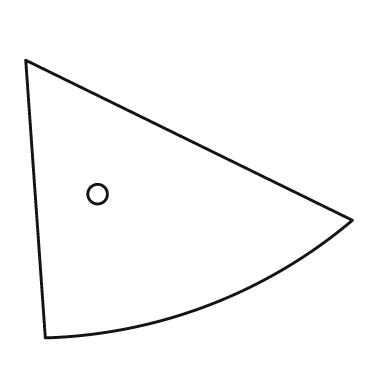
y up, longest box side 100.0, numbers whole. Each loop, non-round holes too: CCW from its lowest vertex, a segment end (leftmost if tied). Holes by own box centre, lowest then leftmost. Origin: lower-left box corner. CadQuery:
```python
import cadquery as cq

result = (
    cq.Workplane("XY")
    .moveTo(6.0, 0.0)
    .threePointArc((56.0, 10.0), (100.0, 36.0))
    .lineTo(0.0, 85.0)
    .close()
    .moveTo(22.0, 44.0)
    .circle(3.0)
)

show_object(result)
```